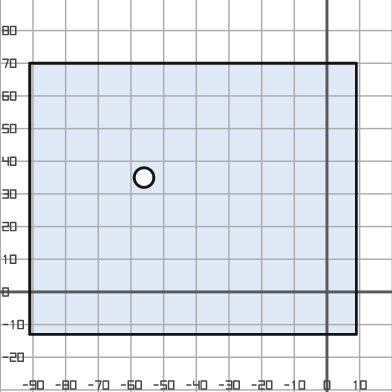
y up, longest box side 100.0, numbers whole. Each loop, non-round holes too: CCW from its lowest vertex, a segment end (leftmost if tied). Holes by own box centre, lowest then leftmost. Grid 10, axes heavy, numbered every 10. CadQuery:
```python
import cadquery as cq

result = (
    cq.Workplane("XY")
    .moveTo(-91.0, -13.0)
    .lineTo(9.0, -13.0)
    .lineTo(9.0, 70.0)
    .lineTo(-91.0, 70.0)
    .close()
    .moveTo(-56.0, 35.0)
    .circle(3.0)
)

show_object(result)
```